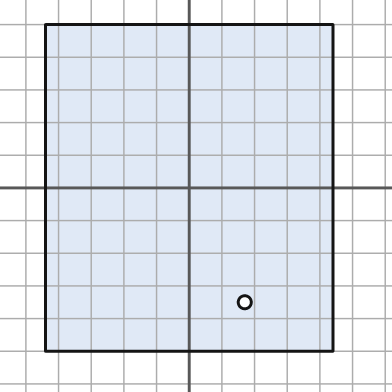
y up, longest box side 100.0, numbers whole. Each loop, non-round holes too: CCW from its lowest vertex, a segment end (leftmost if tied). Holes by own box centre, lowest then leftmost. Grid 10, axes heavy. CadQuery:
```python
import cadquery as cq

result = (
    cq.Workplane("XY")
    .moveTo(-44.0, -50.0)
    .lineTo(44.0, -50.0)
    .lineTo(44.0, 50.0)
    .lineTo(-44.0, 50.0)
    .close()
    .moveTo(17.0, -35.0)
    .circle(2.0)
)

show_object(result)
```